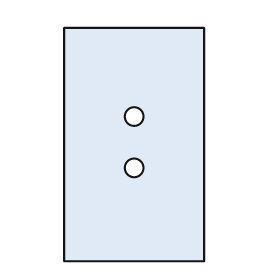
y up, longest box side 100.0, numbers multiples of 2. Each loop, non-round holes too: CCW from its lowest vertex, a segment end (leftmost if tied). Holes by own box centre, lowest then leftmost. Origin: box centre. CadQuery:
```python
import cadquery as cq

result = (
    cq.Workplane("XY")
    .moveTo(-30.0, -50.0)
    .lineTo(30.0, -50.0)
    .lineTo(30.0, 50.0)
    .lineTo(-30.0, 50.0)
    .close()
    .moveTo(0.0, -10.0)
    .circle(4.0)
    .moveTo(0.0, 12.0)
    .circle(4.0)
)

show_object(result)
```